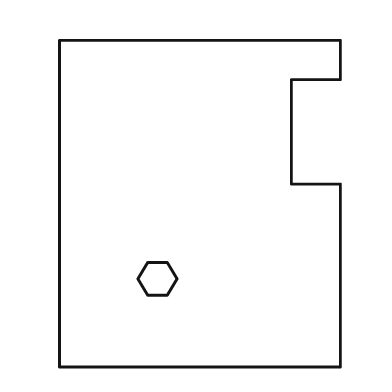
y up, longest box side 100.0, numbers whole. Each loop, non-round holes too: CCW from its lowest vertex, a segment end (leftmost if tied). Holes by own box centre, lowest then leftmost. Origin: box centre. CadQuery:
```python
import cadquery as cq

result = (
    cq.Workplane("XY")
    .moveTo(-43.0, -50.0)
    .lineTo(43.0, -50.0)
    .lineTo(43.0, 6.0)
    .lineTo(28.0, 6.0)
    .lineTo(28.0, 38.0)
    .lineTo(43.0, 38.0)
    .lineTo(43.0, 50.0)
    .lineTo(-43.0, 50.0)
    .close()
    .moveTo(-16.0, -28.0)
    .lineTo(-10.0, -28.0)
    .lineTo(-7.0, -23.0)
    .lineTo(-10.0, -18.0)
    .lineTo(-16.0, -18.0)
    .lineTo(-19.0, -23.0)
    .close()
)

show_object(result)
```